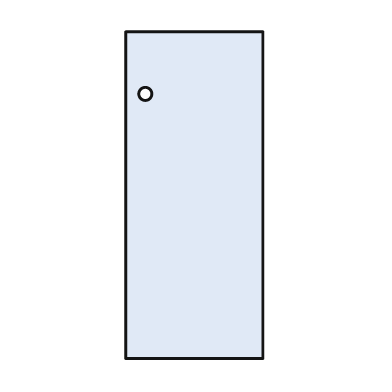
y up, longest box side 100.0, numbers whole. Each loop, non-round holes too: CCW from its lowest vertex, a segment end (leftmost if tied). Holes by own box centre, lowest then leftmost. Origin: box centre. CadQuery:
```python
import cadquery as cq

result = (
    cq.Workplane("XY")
    .moveTo(-21.0, -50.0)
    .lineTo(21.0, -50.0)
    .lineTo(21.0, 50.0)
    .lineTo(-21.0, 50.0)
    .close()
    .moveTo(-15.0, 31.0)
    .circle(2.0)
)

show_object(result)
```